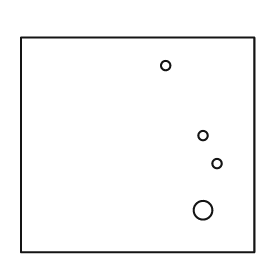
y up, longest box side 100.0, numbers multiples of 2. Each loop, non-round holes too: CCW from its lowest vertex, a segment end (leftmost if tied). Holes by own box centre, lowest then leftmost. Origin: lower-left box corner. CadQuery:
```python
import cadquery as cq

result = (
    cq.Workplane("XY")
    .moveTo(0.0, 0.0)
    .lineTo(100.0, 0.0)
    .lineTo(100.0, 92.0)
    .lineTo(0.0, 92.0)
    .close()
    .moveTo(78.0, 18.0)
    .circle(4.0)
    .moveTo(84.0, 38.0)
    .circle(2.0)
    .moveTo(78.0, 50.0)
    .circle(2.0)
    .moveTo(62.0, 80.0)
    .circle(2.0)
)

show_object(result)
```